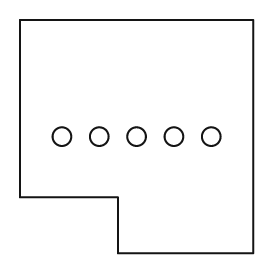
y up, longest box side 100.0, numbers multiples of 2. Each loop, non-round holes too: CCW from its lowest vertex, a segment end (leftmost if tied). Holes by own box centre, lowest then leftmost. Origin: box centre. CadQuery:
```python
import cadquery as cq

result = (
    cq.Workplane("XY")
    .moveTo(-8.0, -50.0)
    .lineTo(50.0, -50.0)
    .lineTo(50.0, 50.0)
    .lineTo(-50.0, 50.0)
    .lineTo(-50.0, -26.0)
    .lineTo(-8.0, -26.0)
    .close()
    .moveTo(-32.0, 0.0)
    .circle(4.0)
    .moveTo(-16.0, 0.0)
    .circle(4.0)
    .moveTo(0.0, 0.0)
    .circle(4.0)
    .moveTo(16.0, 0.0)
    .circle(4.0)
    .moveTo(32.0, 0.0)
    .circle(4.0)
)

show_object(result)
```